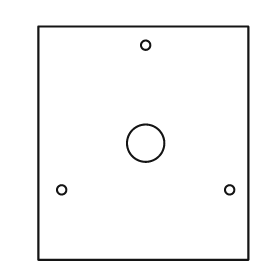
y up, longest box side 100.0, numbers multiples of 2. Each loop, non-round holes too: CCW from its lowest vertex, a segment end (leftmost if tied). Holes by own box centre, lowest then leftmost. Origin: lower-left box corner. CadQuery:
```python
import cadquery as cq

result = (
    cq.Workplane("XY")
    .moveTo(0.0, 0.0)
    .lineTo(90.0, 0.0)
    .lineTo(90.0, 100.0)
    .lineTo(0.0, 100.0)
    .close()
    .moveTo(10.0, 30.0)
    .circle(2.0)
    .moveTo(82.0, 30.0)
    .circle(2.0)
    .moveTo(46.0, 50.0)
    .circle(8.0)
    .moveTo(46.0, 92.0)
    .circle(2.0)
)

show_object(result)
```